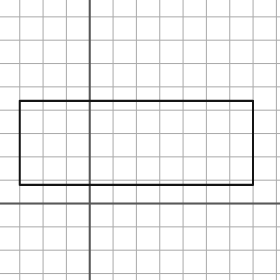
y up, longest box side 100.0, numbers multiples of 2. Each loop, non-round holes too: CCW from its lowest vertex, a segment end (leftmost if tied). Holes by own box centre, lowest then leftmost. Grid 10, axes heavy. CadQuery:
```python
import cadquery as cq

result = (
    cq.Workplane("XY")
    .moveTo(-30.0, 8.0)
    .lineTo(70.0, 8.0)
    .lineTo(70.0, 44.0)
    .lineTo(-30.0, 44.0)
    .close()
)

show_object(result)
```